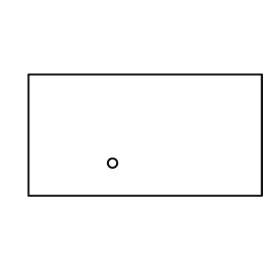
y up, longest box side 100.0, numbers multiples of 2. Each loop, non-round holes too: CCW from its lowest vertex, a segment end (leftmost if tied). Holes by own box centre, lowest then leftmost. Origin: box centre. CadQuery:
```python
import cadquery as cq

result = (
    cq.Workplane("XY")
    .moveTo(-50.0, -26.0)
    .lineTo(50.0, -26.0)
    .lineTo(50.0, 26.0)
    .lineTo(-50.0, 26.0)
    .close()
    .moveTo(-14.0, -12.0)
    .circle(2.0)
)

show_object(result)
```